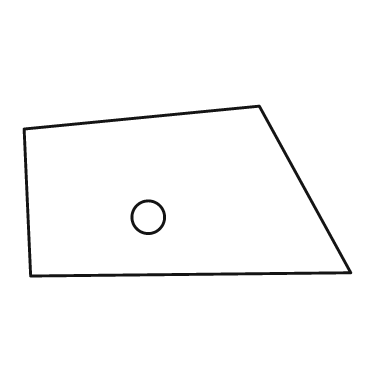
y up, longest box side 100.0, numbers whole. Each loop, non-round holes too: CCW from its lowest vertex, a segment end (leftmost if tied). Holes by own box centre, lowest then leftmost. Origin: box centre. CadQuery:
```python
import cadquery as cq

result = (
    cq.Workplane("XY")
    .moveTo(-48.0, -26.0)
    .lineTo(50.0, -25.0)
    .lineTo(22.0, 26.0)
    .lineTo(-50.0, 19.0)
    .close()
    .moveTo(-12.0, -8.0)
    .circle(5.0)
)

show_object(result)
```